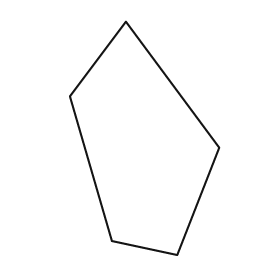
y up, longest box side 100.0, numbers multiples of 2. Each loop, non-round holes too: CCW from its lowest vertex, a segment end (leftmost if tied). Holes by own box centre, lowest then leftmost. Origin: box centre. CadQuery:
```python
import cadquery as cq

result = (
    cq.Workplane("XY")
    .moveTo(14.0, -50.0)
    .lineTo(32.0, -4.0)
    .lineTo(-8.0, 50.0)
    .lineTo(-32.0, 18.0)
    .lineTo(-14.0, -44.0)
    .close()
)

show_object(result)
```